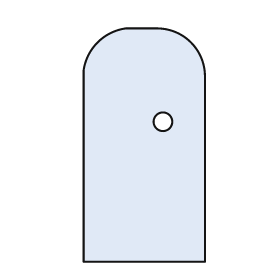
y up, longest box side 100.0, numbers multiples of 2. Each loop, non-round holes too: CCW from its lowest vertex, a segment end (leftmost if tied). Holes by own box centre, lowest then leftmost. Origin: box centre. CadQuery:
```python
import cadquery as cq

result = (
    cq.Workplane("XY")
    .moveTo(-26.0, -50.0)
    .lineTo(26.0, -50.0)
    .lineTo(26.0, 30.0)
    .threePointArc((20.0, 44.0), (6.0, 50.0))
    .lineTo(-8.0, 50.0)
    .threePointArc((-20.0, 44.0), (-26.0, 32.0))
    .close()
    .moveTo(8.0, 10.0)
    .circle(4.0)
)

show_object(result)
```